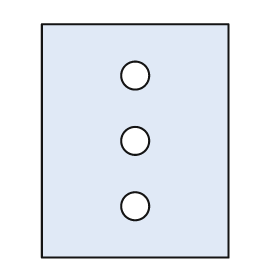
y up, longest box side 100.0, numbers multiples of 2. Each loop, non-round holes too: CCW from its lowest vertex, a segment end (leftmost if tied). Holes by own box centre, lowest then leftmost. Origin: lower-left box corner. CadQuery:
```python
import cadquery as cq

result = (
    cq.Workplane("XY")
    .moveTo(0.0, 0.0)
    .lineTo(80.0, 0.0)
    .lineTo(80.0, 100.0)
    .lineTo(0.0, 100.0)
    .close()
    .moveTo(40.0, 22.0)
    .circle(6.0)
    .moveTo(40.0, 50.0)
    .circle(6.0)
    .moveTo(40.0, 78.0)
    .circle(6.0)
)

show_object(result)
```